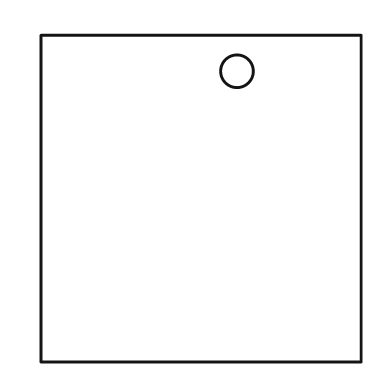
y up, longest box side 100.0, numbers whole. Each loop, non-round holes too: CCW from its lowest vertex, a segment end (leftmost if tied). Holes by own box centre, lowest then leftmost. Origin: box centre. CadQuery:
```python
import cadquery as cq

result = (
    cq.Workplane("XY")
    .moveTo(-49.0, -50.0)
    .lineTo(49.0, -50.0)
    .lineTo(49.0, 50.0)
    .lineTo(-49.0, 50.0)
    .close()
    .moveTo(11.0, 39.0)
    .circle(5.0)
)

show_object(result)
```